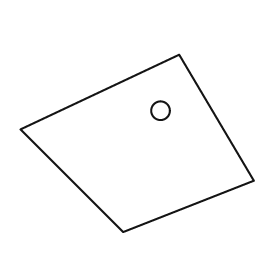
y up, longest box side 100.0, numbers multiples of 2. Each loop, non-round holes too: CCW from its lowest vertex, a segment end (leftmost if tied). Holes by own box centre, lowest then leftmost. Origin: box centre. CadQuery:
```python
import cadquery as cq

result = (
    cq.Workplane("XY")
    .moveTo(-6.0, -38.0)
    .lineTo(50.0, -16.0)
    .lineTo(18.0, 38.0)
    .lineTo(-50.0, 6.0)
    .close()
    .moveTo(10.0, 14.0)
    .circle(4.0)
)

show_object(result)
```